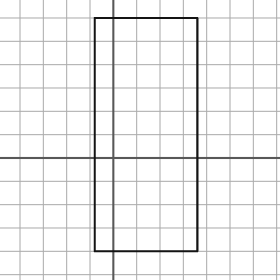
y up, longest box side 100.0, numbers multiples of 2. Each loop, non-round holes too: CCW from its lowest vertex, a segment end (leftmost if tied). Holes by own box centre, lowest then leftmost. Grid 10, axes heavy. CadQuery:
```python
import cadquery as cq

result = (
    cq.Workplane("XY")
    .moveTo(-8.0, -40.0)
    .lineTo(36.0, -40.0)
    .lineTo(36.0, 60.0)
    .lineTo(-8.0, 60.0)
    .close()
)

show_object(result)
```